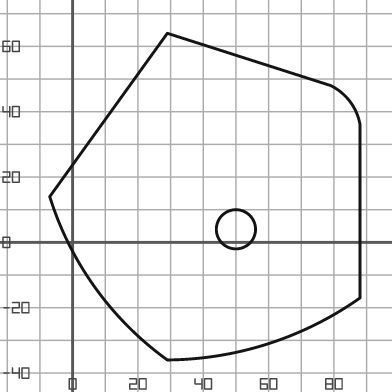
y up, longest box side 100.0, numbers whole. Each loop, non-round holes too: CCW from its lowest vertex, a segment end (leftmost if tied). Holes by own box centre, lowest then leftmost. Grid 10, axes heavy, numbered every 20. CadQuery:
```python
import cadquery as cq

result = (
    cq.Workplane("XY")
    .moveTo(29.0, -36.0)
    .threePointArc((60.0, -31.0), (88.0, -17.0))
    .lineTo(88.0, 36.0)
    .threePointArc((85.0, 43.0), (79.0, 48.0))
    .lineTo(29.0, 64.0)
    .lineTo(-7.0, 14.0)
    .threePointArc((7.0, -14.0), (29.0, -36.0))
    .close()
    .moveTo(50.0, 4.0)
    .circle(6.0)
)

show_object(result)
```